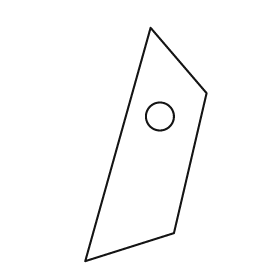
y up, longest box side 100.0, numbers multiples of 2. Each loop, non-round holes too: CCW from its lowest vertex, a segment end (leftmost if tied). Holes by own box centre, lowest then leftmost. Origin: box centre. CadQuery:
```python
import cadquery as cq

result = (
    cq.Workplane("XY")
    .moveTo(-26.0, -50.0)
    .lineTo(12.0, -38.0)
    .lineTo(26.0, 22.0)
    .lineTo(2.0, 50.0)
    .close()
    .moveTo(6.0, 12.0)
    .circle(6.0)
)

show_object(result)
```